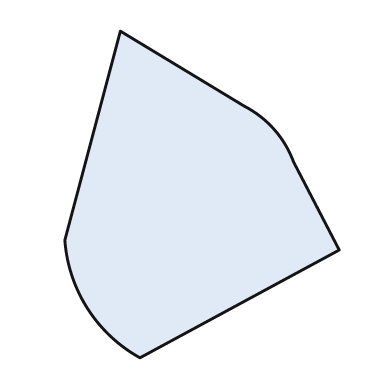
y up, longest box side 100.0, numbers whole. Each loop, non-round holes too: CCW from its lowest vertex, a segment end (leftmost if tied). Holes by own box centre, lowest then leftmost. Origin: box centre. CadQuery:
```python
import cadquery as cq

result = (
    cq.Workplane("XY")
    .moveTo(-19.0, -50.0)
    .lineTo(42.0, -17.0)
    .lineTo(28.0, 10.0)
    .threePointArc((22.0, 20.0), (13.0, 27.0))
    .lineTo(-25.0, 50.0)
    .lineTo(-42.0, -14.0)
    .threePointArc((-35.0, -35.0), (-19.0, -50.0))
    .close()
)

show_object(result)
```